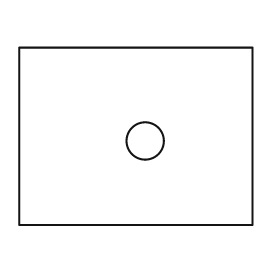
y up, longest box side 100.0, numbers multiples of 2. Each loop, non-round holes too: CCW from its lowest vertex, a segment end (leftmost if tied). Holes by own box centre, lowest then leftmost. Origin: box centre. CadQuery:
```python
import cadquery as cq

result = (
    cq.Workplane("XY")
    .moveTo(-50.0, -38.0)
    .lineTo(50.0, -38.0)
    .lineTo(50.0, 38.0)
    .lineTo(-50.0, 38.0)
    .close()
    .moveTo(4.0, -2.0)
    .circle(8.0)
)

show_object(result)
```